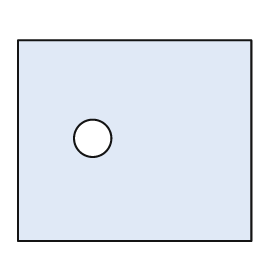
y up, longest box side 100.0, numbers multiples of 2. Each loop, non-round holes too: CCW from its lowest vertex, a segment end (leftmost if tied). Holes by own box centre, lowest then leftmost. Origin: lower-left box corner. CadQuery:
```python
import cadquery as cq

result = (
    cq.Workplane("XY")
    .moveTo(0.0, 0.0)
    .lineTo(100.0, 0.0)
    .lineTo(100.0, 86.0)
    .lineTo(0.0, 86.0)
    .close()
    .moveTo(32.0, 44.0)
    .circle(8.0)
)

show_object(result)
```